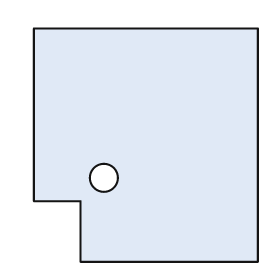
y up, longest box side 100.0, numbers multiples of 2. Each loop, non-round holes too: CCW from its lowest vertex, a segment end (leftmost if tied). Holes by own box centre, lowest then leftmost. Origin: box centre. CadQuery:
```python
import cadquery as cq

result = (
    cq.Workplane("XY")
    .moveTo(-28.0, -50.0)
    .lineTo(48.0, -50.0)
    .lineTo(48.0, 50.0)
    .lineTo(-48.0, 50.0)
    .lineTo(-48.0, -24.0)
    .lineTo(-28.0, -24.0)
    .close()
    .moveTo(-18.0, -14.0)
    .circle(6.0)
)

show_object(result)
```